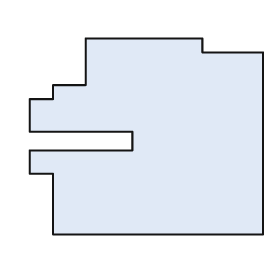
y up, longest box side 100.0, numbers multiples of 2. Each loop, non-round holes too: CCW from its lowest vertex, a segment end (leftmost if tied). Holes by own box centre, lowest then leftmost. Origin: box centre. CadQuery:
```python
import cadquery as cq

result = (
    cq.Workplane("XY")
    .moveTo(-40.0, -42.0)
    .lineTo(50.0, -42.0)
    .lineTo(50.0, 36.0)
    .lineTo(24.0, 36.0)
    .lineTo(24.0, 42.0)
    .lineTo(-26.0, 42.0)
    .lineTo(-26.0, 22.0)
    .lineTo(-40.0, 22.0)
    .lineTo(-40.0, 16.0)
    .lineTo(-50.0, 16.0)
    .lineTo(-50.0, 2.0)
    .lineTo(-6.0, 2.0)
    .lineTo(-6.0, -6.0)
    .lineTo(-50.0, -6.0)
    .lineTo(-50.0, -16.0)
    .lineTo(-40.0, -16.0)
    .close()
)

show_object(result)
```